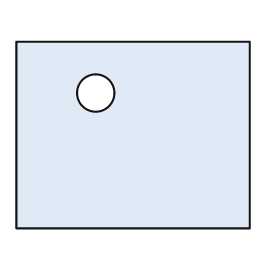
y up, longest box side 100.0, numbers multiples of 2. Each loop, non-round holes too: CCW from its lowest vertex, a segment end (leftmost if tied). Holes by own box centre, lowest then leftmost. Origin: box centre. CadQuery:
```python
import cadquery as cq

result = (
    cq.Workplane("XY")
    .moveTo(-50.0, -40.0)
    .lineTo(50.0, -40.0)
    .lineTo(50.0, 40.0)
    .lineTo(-50.0, 40.0)
    .close()
    .moveTo(-16.0, 18.0)
    .circle(8.0)
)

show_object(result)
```